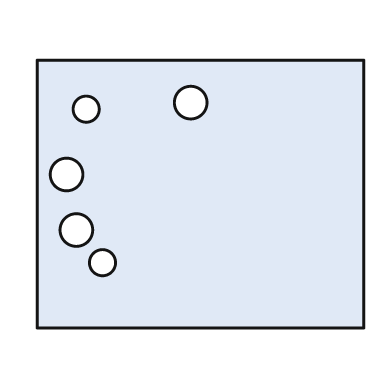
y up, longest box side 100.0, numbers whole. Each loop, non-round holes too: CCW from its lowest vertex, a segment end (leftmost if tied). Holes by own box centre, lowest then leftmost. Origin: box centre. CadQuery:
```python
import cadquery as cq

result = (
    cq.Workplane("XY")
    .moveTo(-50.0, -41.0)
    .lineTo(50.0, -41.0)
    .lineTo(50.0, 41.0)
    .lineTo(-50.0, 41.0)
    .close()
    .moveTo(-30.0, -21.0)
    .circle(4.0)
    .moveTo(-38.0, -11.0)
    .circle(5.0)
    .moveTo(-41.0, 6.0)
    .circle(5.0)
    .moveTo(-35.0, 26.0)
    .circle(4.0)
    .moveTo(-3.0, 28.0)
    .circle(5.0)
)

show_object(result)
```